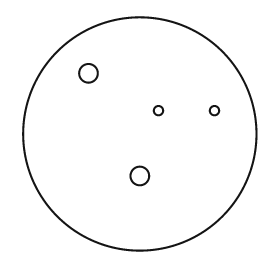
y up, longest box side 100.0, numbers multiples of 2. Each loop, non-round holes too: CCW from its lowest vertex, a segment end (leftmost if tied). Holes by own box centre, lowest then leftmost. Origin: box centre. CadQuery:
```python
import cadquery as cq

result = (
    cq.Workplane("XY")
    .moveTo(0.0, 0.0)
    .circle(50.0)
    .moveTo(0.0, -18.0)
    .circle(4.0)
    .moveTo(8.0, 10.0)
    .circle(2.0)
    .moveTo(32.0, 10.0)
    .circle(2.0)
    .moveTo(-22.0, 26.0)
    .circle(4.0)
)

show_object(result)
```